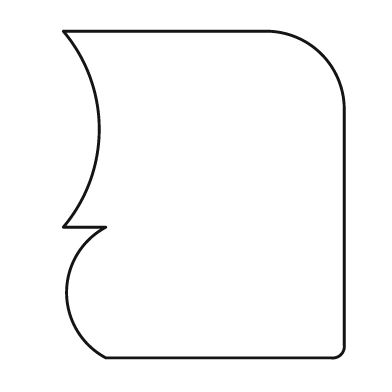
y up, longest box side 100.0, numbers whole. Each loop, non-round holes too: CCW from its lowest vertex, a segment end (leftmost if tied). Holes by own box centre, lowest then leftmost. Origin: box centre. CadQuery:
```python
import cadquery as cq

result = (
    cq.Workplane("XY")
    .moveTo(-30.0, -50.0)
    .lineTo(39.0, -50.0)
    .threePointArc((42.0, -49.0), (43.0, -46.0))
    .lineTo(43.0, 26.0)
    .threePointArc((36.0, 43.0), (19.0, 50.0))
    .lineTo(-43.0, 50.0)
    .threePointArc((-32.0, 20.0), (-43.0, -10.0))
    .lineTo(-30.0, -10.0)
    .threePointArc((-42.0, -30.0), (-30.0, -50.0))
    .close()
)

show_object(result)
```